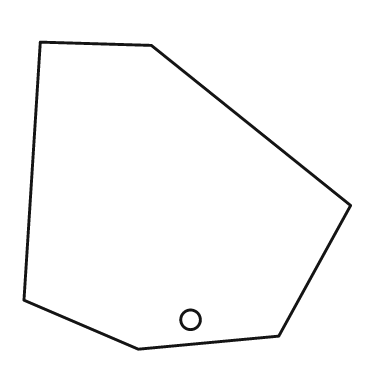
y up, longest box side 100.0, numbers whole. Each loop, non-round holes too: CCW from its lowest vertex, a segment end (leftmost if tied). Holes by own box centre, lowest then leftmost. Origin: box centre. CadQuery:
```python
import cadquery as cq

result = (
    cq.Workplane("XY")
    .moveTo(-15.0, -47.0)
    .lineTo(28.0, -43.0)
    .lineTo(50.0, -3.0)
    .lineTo(-11.0, 46.0)
    .lineTo(-45.0, 47.0)
    .lineTo(-50.0, -32.0)
    .close()
    .moveTo(1.0, -38.0)
    .circle(3.0)
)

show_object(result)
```